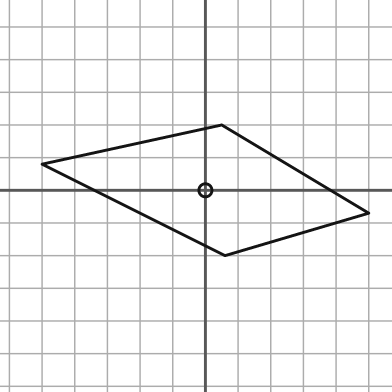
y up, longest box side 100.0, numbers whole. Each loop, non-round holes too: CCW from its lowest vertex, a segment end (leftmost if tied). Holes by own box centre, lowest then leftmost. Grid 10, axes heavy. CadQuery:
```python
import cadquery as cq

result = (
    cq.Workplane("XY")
    .moveTo(6.0, -20.0)
    .lineTo(50.0, -7.0)
    .lineTo(5.0, 20.0)
    .lineTo(-50.0, 8.0)
    .close()
    .moveTo(0.0, 0.0)
    .circle(2.0)
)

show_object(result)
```